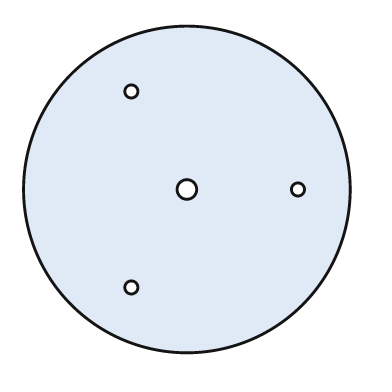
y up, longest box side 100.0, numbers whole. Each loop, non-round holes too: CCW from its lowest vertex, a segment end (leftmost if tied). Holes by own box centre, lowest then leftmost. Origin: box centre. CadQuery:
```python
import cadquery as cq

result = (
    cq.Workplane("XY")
    .moveTo(0.0, 0.0)
    .circle(50.0)
    .moveTo(-17.0, -30.0)
    .circle(2.0)
    .moveTo(0.0, 0.0)
    .circle(3.0)
    .moveTo(34.0, 0.0)
    .circle(2.0)
    .moveTo(-17.0, 30.0)
    .circle(2.0)
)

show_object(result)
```